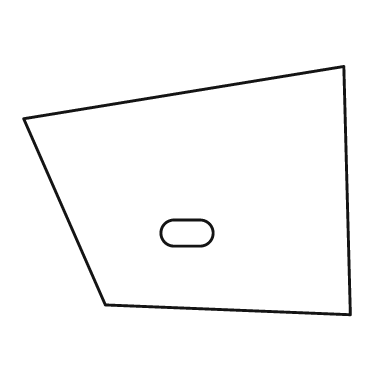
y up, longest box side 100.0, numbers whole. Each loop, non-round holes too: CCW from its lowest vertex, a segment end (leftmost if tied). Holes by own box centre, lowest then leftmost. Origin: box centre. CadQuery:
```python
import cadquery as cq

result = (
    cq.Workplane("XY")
    .moveTo(50.0, -38.0)
    .lineTo(48.0, 38.0)
    .lineTo(-50.0, 22.0)
    .lineTo(-25.0, -35.0)
    .close()
    .moveTo(-4.0, -17.0)
    .lineTo(4.0, -17.0)
    .threePointArc((8.0, -13.0), (4.0, -9.0))
    .lineTo(-4.0, -9.0)
    .threePointArc((-8.0, -13.0), (-4.0, -17.0))
    .close()
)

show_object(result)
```